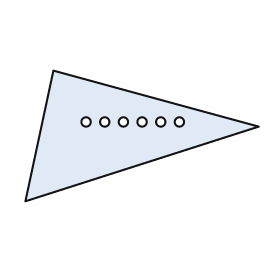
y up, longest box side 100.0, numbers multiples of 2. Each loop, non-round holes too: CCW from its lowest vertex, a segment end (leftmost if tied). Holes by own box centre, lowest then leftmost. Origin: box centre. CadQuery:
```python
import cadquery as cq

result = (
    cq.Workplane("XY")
    .moveTo(-50.0, -28.0)
    .lineTo(50.0, 4.0)
    .lineTo(-38.0, 28.0)
    .close()
    .moveTo(-24.0, 6.0)
    .circle(2.0)
    .moveTo(-16.0, 6.0)
    .circle(2.0)
    .moveTo(-8.0, 6.0)
    .circle(2.0)
    .moveTo(0.0, 6.0)
    .circle(2.0)
    .moveTo(8.0, 6.0)
    .circle(2.0)
    .moveTo(16.0, 6.0)
    .circle(2.0)
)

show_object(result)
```